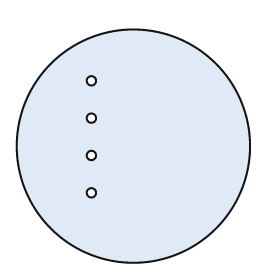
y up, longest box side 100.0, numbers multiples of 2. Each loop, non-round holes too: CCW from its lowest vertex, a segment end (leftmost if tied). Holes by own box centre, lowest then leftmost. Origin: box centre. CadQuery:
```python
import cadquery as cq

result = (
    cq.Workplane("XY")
    .moveTo(0.0, 0.0)
    .circle(50.0)
    .moveTo(-18.0, -20.0)
    .circle(2.0)
    .moveTo(-18.0, -4.0)
    .circle(2.0)
    .moveTo(-18.0, 12.0)
    .circle(2.0)
    .moveTo(-18.0, 28.0)
    .circle(2.0)
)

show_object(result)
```